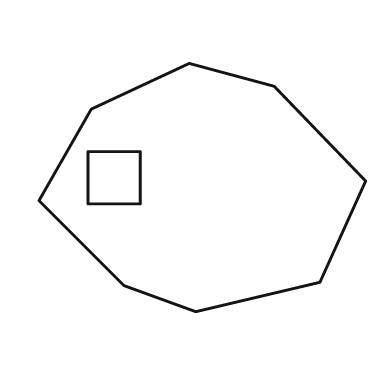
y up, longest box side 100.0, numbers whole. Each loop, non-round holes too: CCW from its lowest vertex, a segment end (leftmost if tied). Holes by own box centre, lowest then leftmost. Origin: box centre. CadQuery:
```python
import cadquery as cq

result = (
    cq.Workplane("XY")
    .moveTo(-2.0, -38.0)
    .lineTo(36.0, -29.0)
    .lineTo(50.0, 2.0)
    .lineTo(22.0, 31.0)
    .lineTo(-4.0, 38.0)
    .lineTo(-34.0, 24.0)
    .lineTo(-50.0, -4.0)
    .lineTo(-24.0, -30.0)
    .close()
    .moveTo(-35.0, -5.0)
    .lineTo(-19.0, -5.0)
    .lineTo(-19.0, 11.0)
    .lineTo(-35.0, 11.0)
    .close()
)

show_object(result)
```